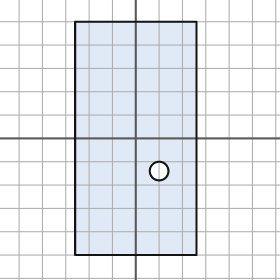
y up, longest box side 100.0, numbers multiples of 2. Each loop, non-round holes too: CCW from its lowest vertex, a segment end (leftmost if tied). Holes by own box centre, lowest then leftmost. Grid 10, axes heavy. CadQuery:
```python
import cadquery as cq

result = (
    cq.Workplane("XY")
    .moveTo(-26.0, -50.0)
    .lineTo(26.0, -50.0)
    .lineTo(26.0, 50.0)
    .lineTo(-26.0, 50.0)
    .close()
    .moveTo(10.0, -14.0)
    .circle(4.0)
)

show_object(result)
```